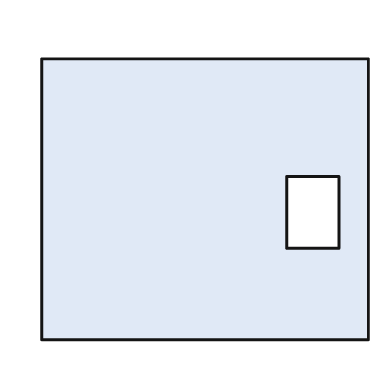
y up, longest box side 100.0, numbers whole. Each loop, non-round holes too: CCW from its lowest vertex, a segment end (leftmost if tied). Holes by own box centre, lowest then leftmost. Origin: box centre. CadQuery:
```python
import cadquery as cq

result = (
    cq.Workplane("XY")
    .moveTo(-50.0, -43.0)
    .lineTo(50.0, -43.0)
    .lineTo(50.0, 43.0)
    .lineTo(-50.0, 43.0)
    .close()
    .moveTo(25.0, -15.0)
    .lineTo(41.0, -15.0)
    .lineTo(41.0, 7.0)
    .lineTo(25.0, 7.0)
    .close()
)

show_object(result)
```